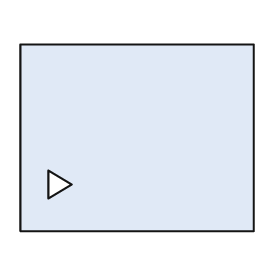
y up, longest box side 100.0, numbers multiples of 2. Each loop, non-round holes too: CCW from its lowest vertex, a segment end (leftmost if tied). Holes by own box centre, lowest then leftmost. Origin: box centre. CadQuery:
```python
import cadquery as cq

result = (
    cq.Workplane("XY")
    .moveTo(-50.0, -40.0)
    .lineTo(50.0, -40.0)
    .lineTo(50.0, 40.0)
    .lineTo(-50.0, 40.0)
    .close()
    .moveTo(-38.0, -26.0)
    .lineTo(-28.0, -20.0)
    .lineTo(-38.0, -14.0)
    .close()
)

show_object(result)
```